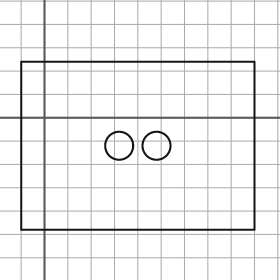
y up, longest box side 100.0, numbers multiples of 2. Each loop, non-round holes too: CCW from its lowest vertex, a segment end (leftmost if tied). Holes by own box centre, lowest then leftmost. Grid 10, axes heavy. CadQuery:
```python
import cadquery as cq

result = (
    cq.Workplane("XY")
    .moveTo(-10.0, -48.0)
    .lineTo(90.0, -48.0)
    .lineTo(90.0, 24.0)
    .lineTo(-10.0, 24.0)
    .close()
    .moveTo(32.0, -12.0)
    .circle(6.0)
    .moveTo(48.0, -12.0)
    .circle(6.0)
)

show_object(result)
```